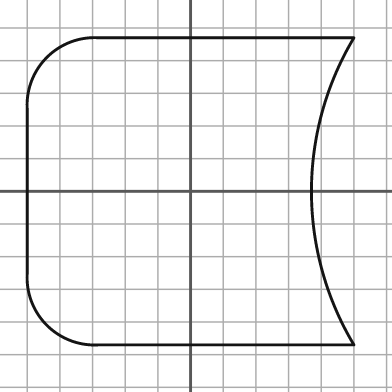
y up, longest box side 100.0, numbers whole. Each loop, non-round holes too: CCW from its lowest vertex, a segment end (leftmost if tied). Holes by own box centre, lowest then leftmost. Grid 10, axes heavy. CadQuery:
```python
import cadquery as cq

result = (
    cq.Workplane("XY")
    .moveTo(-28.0, -47.0)
    .lineTo(50.0, -47.0)
    .threePointArc((37.0, 0.0), (50.0, 47.0))
    .lineTo(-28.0, 47.0)
    .threePointArc((-44.0, 41.0), (-50.0, 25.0))
    .lineTo(-50.0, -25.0)
    .threePointArc((-44.0, -41.0), (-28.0, -47.0))
    .close()
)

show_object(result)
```